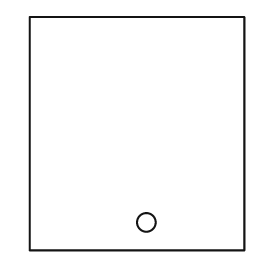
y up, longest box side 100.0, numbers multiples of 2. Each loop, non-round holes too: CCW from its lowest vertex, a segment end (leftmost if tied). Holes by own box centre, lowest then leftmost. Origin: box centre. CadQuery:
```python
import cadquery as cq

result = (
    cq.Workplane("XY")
    .moveTo(-46.0, -50.0)
    .lineTo(46.0, -50.0)
    .lineTo(46.0, 50.0)
    .lineTo(-46.0, 50.0)
    .close()
    .moveTo(4.0, -38.0)
    .circle(4.0)
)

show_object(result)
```